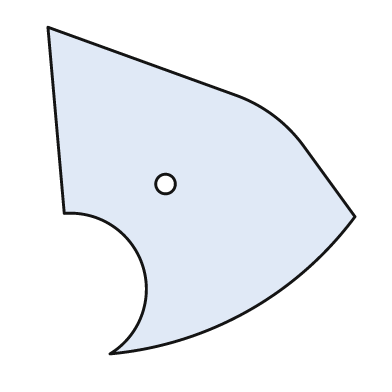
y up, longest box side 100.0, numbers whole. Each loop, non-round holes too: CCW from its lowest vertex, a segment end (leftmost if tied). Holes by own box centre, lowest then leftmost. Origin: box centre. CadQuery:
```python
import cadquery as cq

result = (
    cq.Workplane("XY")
    .moveTo(-28.0, -50.0)
    .threePointArc((14.0, -37.0), (47.0, -8.0))
    .lineTo(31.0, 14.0)
    .threePointArc((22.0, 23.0), (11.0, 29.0))
    .lineTo(-47.0, 50.0)
    .lineTo(-42.0, -7.0)
    .threePointArc((-18.0, -23.0), (-28.0, -50.0))
    .close()
    .moveTo(-11.0, 2.0)
    .circle(3.0)
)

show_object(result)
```